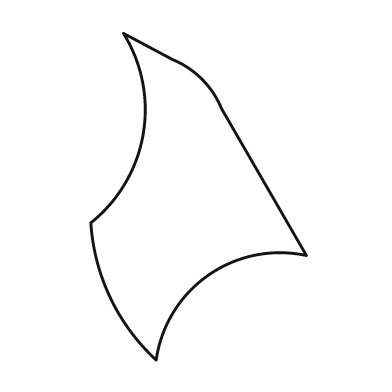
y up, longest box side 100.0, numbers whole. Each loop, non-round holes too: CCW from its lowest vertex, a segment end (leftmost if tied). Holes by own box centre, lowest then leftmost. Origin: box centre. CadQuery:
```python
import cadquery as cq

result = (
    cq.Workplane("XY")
    .moveTo(-13.0, -50.0)
    .threePointArc((3.0, -24.0), (33.0, -18.0))
    .lineTo(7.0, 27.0)
    .threePointArc((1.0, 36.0), (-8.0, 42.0))
    .lineTo(-23.0, 50.0)
    .threePointArc((-17.0, 19.0), (-33.0, -8.0))
    .threePointArc((-27.0, -31.0), (-13.0, -50.0))
    .close()
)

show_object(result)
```